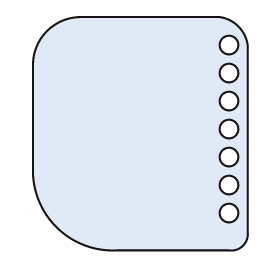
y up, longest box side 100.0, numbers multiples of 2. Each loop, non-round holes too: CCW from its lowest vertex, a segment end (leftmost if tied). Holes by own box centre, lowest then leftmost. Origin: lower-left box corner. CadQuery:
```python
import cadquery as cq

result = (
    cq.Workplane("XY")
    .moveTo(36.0, 0.0)
    .lineTo(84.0, 0.0)
    .threePointArc((90.0, 2.0), (92.0, 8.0))
    .lineTo(92.0, 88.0)
    .threePointArc((88.0, 96.0), (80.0, 100.0))
    .lineTo(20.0, 100.0)
    .threePointArc((6.0, 94.0), (0.0, 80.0))
    .lineTo(0.0, 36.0)
    .threePointArc((10.0, 10.0), (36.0, 0.0))
    .close()
    .moveTo(84.0, 16.0)
    .circle(4.0)
    .moveTo(84.0, 28.0)
    .circle(4.0)
    .moveTo(84.0, 40.0)
    .circle(4.0)
    .moveTo(84.0, 52.0)
    .circle(4.0)
    .moveTo(84.0, 64.0)
    .circle(4.0)
    .moveTo(84.0, 76.0)
    .circle(4.0)
    .moveTo(84.0, 88.0)
    .circle(4.0)
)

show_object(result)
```